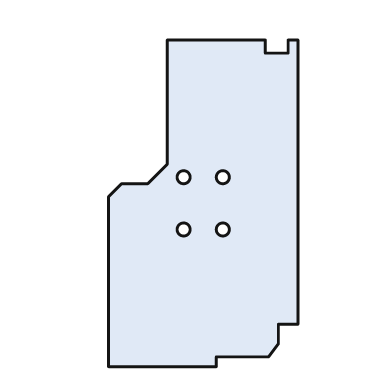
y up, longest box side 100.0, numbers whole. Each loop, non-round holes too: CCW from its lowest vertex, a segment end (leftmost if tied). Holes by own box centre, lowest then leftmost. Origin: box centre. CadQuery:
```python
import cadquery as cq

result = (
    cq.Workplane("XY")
    .moveTo(-29.0, -50.0)
    .lineTo(4.0, -50.0)
    .lineTo(4.0, -47.0)
    .lineTo(20.0, -47.0)
    .lineTo(23.0, -43.0)
    .lineTo(23.0, -37.0)
    .lineTo(29.0, -37.0)
    .lineTo(29.0, 50.0)
    .lineTo(26.0, 50.0)
    .lineTo(26.0, 46.0)
    .lineTo(19.0, 46.0)
    .lineTo(19.0, 50.0)
    .lineTo(-11.0, 50.0)
    .lineTo(-11.0, 12.0)
    .lineTo(-17.0, 6.0)
    .lineTo(-25.0, 6.0)
    .lineTo(-29.0, 2.0)
    .close()
    .moveTo(-6.0, -8.0)
    .circle(2.0)
    .moveTo(6.0, -8.0)
    .circle(2.0)
    .moveTo(-6.0, 8.0)
    .circle(2.0)
    .moveTo(6.0, 8.0)
    .circle(2.0)
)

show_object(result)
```